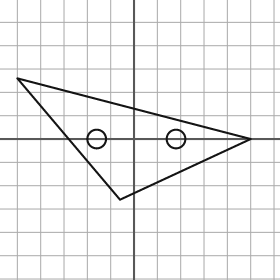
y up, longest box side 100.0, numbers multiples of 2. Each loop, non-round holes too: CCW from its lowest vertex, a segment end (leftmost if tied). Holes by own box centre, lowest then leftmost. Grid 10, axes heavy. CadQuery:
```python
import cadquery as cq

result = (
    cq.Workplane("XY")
    .moveTo(-6.0, -26.0)
    .lineTo(50.0, 0.0)
    .lineTo(-50.0, 26.0)
    .close()
    .moveTo(-16.0, 0.0)
    .circle(4.0)
    .moveTo(18.0, 0.0)
    .circle(4.0)
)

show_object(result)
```